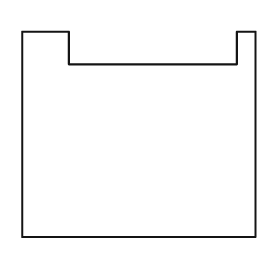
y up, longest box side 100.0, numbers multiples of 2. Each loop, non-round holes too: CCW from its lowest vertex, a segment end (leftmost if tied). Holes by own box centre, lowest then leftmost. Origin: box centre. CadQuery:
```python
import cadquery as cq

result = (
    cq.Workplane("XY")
    .moveTo(-50.0, -44.0)
    .lineTo(50.0, -44.0)
    .lineTo(50.0, 44.0)
    .lineTo(42.0, 44.0)
    .lineTo(42.0, 30.0)
    .lineTo(-30.0, 30.0)
    .lineTo(-30.0, 44.0)
    .lineTo(-50.0, 44.0)
    .close()
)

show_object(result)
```